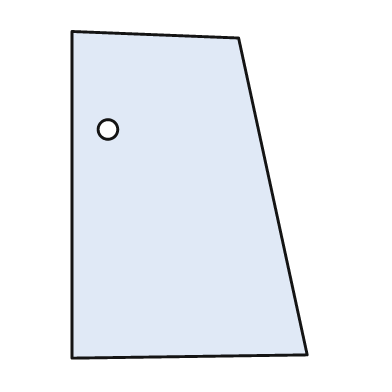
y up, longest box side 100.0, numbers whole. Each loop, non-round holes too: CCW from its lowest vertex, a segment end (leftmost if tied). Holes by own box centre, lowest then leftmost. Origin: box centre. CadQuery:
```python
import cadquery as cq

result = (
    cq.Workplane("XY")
    .moveTo(-36.0, -50.0)
    .lineTo(36.0, -49.0)
    .lineTo(15.0, 48.0)
    .lineTo(-36.0, 50.0)
    .close()
    .moveTo(-25.0, 20.0)
    .circle(3.0)
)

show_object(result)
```